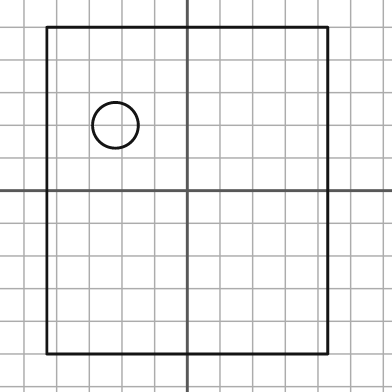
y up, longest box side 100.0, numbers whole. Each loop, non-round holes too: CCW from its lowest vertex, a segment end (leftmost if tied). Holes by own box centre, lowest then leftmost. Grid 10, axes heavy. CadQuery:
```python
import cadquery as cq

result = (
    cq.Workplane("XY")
    .moveTo(-43.0, -50.0)
    .lineTo(43.0, -50.0)
    .lineTo(43.0, 50.0)
    .lineTo(-43.0, 50.0)
    .close()
    .moveTo(-22.0, 20.0)
    .circle(7.0)
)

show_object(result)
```